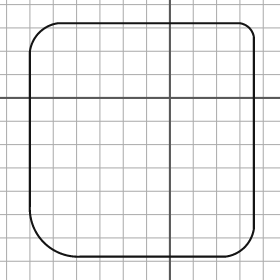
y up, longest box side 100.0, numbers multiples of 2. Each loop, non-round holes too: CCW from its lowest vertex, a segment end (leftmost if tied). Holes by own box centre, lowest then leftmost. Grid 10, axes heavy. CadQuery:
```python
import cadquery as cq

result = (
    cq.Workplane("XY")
    .moveTo(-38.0, -68.0)
    .lineTo(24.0, -68.0)
    .threePointArc((32.0, -64.0), (36.0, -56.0))
    .lineTo(36.0, 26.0)
    .threePointArc((34.0, 30.0), (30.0, 32.0))
    .lineTo(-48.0, 32.0)
    .threePointArc((-56.0, 28.0), (-60.0, 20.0))
    .lineTo(-60.0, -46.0)
    .threePointArc((-54.0, -62.0), (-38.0, -68.0))
    .close()
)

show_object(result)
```